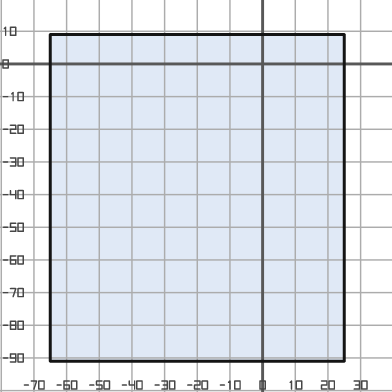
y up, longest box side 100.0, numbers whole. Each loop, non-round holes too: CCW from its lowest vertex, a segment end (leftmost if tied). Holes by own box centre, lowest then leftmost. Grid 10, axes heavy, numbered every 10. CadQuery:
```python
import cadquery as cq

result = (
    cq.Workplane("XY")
    .moveTo(-65.0, -91.0)
    .lineTo(25.0, -91.0)
    .lineTo(25.0, 9.0)
    .lineTo(-65.0, 9.0)
    .close()
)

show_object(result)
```